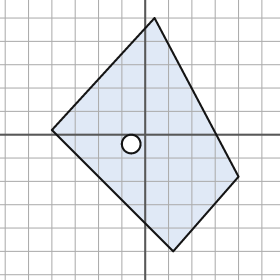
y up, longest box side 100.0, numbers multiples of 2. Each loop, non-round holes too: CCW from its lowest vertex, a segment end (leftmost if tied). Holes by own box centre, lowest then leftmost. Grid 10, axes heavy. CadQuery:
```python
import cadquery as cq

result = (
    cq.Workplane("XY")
    .moveTo(12.0, -50.0)
    .lineTo(40.0, -18.0)
    .lineTo(4.0, 50.0)
    .lineTo(-40.0, 2.0)
    .close()
    .moveTo(-6.0, -4.0)
    .circle(4.0)
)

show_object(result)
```